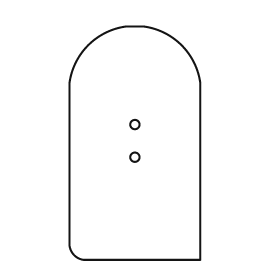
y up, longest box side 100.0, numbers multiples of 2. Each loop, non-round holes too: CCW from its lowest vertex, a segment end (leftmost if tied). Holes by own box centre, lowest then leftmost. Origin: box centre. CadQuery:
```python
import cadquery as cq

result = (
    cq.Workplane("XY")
    .moveTo(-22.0, -50.0)
    .lineTo(28.0, -50.0)
    .lineTo(28.0, 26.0)
    .threePointArc((20.0, 42.0), (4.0, 50.0))
    .lineTo(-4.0, 50.0)
    .threePointArc((-20.0, 42.0), (-28.0, 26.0))
    .lineTo(-28.0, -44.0)
    .threePointArc((-26.0, -48.0), (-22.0, -50.0))
    .close()
    .moveTo(0.0, -6.0)
    .circle(2.0)
    .moveTo(0.0, 8.0)
    .circle(2.0)
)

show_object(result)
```